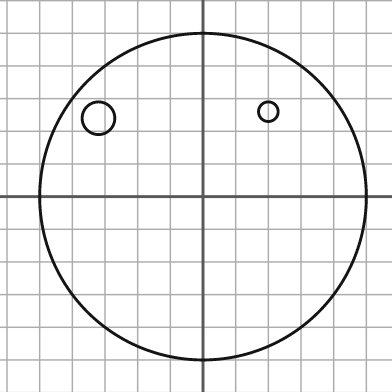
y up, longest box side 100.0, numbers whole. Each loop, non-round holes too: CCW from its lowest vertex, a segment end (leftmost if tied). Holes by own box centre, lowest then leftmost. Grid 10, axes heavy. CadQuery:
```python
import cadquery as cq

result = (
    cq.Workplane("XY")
    .moveTo(0.0, 0.0)
    .circle(50.0)
    .moveTo(-32.0, 24.0)
    .circle(5.0)
    .moveTo(20.0, 26.0)
    .circle(3.0)
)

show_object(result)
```